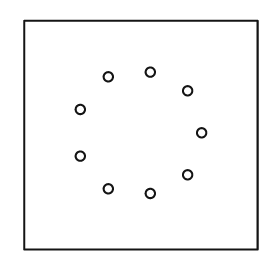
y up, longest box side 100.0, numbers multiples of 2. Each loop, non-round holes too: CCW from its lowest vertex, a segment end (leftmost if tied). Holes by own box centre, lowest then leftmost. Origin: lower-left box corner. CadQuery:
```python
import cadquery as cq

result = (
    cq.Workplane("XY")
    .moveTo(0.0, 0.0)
    .lineTo(100.0, 0.0)
    .lineTo(100.0, 98.0)
    .lineTo(0.0, 98.0)
    .close()
    .moveTo(54.0, 24.0)
    .circle(2.0)
    .moveTo(36.0, 26.0)
    .circle(2.0)
    .moveTo(70.0, 32.0)
    .circle(2.0)
    .moveTo(24.0, 40.0)
    .circle(2.0)
    .moveTo(76.0, 50.0)
    .circle(2.0)
    .moveTo(24.0, 60.0)
    .circle(2.0)
    .moveTo(70.0, 68.0)
    .circle(2.0)
    .moveTo(36.0, 74.0)
    .circle(2.0)
    .moveTo(54.0, 76.0)
    .circle(2.0)
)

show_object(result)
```